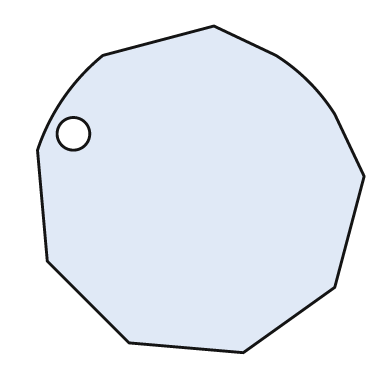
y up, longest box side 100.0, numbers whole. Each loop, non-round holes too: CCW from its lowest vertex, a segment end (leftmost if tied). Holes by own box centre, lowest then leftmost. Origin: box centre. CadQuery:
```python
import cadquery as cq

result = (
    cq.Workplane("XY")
    .moveTo(13.0, -50.0)
    .lineTo(41.0, -30.0)
    .lineTo(50.0, 4.0)
    .lineTo(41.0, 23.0)
    .threePointArc((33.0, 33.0), (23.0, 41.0))
    .lineTo(4.0, 50.0)
    .lineTo(-30.0, 41.0)
    .threePointArc((-42.0, 28.0), (-50.0, 12.0))
    .lineTo(-47.0, -22.0)
    .lineTo(-22.0, -47.0)
    .close()
    .moveTo(-39.0, 17.0)
    .circle(5.0)
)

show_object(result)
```